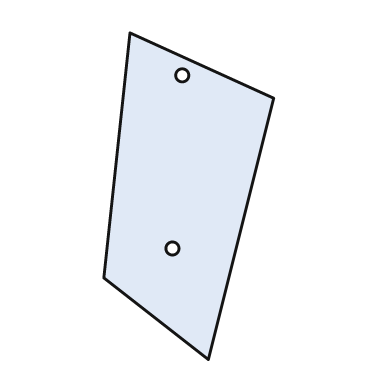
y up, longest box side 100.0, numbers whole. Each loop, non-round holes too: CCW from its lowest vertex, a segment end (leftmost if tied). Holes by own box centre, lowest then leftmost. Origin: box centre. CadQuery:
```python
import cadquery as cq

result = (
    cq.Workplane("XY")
    .moveTo(6.0, -50.0)
    .lineTo(26.0, 30.0)
    .lineTo(-18.0, 50.0)
    .lineTo(-26.0, -25.0)
    .close()
    .moveTo(-5.0, -16.0)
    .circle(2.0)
    .moveTo(-2.0, 37.0)
    .circle(2.0)
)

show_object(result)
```